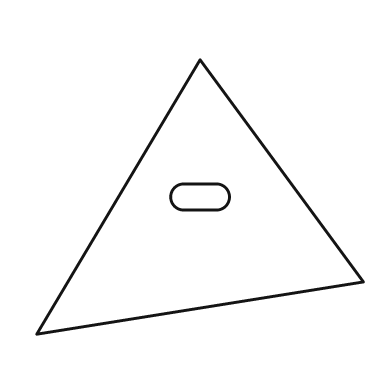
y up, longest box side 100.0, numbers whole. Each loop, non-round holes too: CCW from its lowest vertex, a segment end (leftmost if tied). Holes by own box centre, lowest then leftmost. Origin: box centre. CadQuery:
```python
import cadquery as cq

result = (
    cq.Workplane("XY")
    .moveTo(-50.0, -42.0)
    .lineTo(50.0, -26.0)
    .lineTo(0.0, 42.0)
    .close()
    .moveTo(-5.0, -4.0)
    .lineTo(5.0, -4.0)
    .threePointArc((9.0, 0.0), (5.0, 4.0))
    .lineTo(-5.0, 4.0)
    .threePointArc((-9.0, 0.0), (-5.0, -4.0))
    .close()
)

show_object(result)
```